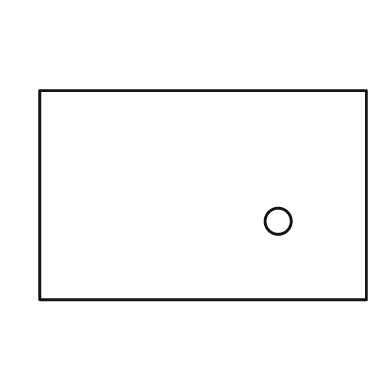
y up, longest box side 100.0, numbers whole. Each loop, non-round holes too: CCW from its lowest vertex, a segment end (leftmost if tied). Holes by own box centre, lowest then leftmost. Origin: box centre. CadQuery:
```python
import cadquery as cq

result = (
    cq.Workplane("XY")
    .moveTo(-50.0, -32.0)
    .lineTo(50.0, -32.0)
    .lineTo(50.0, 32.0)
    .lineTo(-50.0, 32.0)
    .close()
    .moveTo(23.0, -8.0)
    .circle(4.0)
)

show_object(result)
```